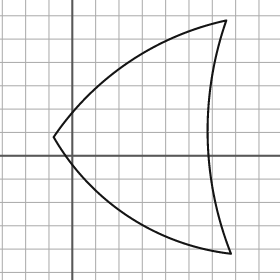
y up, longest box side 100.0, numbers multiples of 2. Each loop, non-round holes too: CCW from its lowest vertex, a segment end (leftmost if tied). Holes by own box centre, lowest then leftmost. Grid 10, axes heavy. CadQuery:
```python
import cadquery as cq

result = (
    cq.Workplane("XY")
    .moveTo(68.0, -42.0)
    .threePointArc((58.0, 8.0), (66.0, 58.0))
    .threePointArc((24.0, 40.0), (-8.0, 8.0))
    .threePointArc((24.0, -26.0), (68.0, -42.0))
    .close()
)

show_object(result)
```